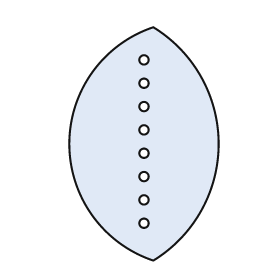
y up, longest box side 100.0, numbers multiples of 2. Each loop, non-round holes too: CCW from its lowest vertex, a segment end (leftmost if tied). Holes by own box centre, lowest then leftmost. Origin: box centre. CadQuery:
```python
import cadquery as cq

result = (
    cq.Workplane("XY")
    .moveTo(4.0, -50.0)
    .threePointArc((32.0, 0.0), (4.0, 50.0))
    .threePointArc((-32.0, 0.0), (4.0, -50.0))
    .close()
    .moveTo(0.0, -34.0)
    .circle(2.0)
    .moveTo(0.0, -24.0)
    .circle(2.0)
    .moveTo(0.0, -14.0)
    .circle(2.0)
    .moveTo(0.0, -4.0)
    .circle(2.0)
    .moveTo(0.0, 6.0)
    .circle(2.0)
    .moveTo(0.0, 16.0)
    .circle(2.0)
    .moveTo(0.0, 26.0)
    .circle(2.0)
    .moveTo(0.0, 36.0)
    .circle(2.0)
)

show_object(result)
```